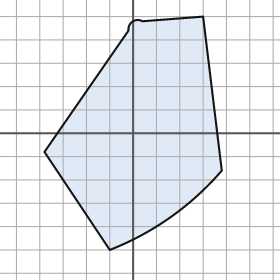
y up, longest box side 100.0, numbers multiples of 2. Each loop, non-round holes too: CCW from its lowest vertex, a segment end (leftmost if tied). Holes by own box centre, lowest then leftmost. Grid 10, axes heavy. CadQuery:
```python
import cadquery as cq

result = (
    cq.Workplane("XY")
    .moveTo(-10.0, -50.0)
    .threePointArc((16.0, -36.0), (38.0, -16.0))
    .lineTo(30.0, 50.0)
    .lineTo(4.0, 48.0)
    .threePointArc((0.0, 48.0), (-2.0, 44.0))
    .lineTo(-38.0, -8.0)
    .close()
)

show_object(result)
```